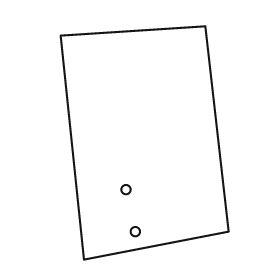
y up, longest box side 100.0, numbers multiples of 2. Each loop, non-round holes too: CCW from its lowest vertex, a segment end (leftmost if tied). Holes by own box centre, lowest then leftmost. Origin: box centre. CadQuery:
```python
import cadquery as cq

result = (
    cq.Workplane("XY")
    .moveTo(-26.0, -50.0)
    .lineTo(36.0, -38.0)
    .lineTo(26.0, 50.0)
    .lineTo(-36.0, 46.0)
    .close()
    .moveTo(-4.0, -38.0)
    .circle(2.0)
    .moveTo(-8.0, -20.0)
    .circle(2.0)
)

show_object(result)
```